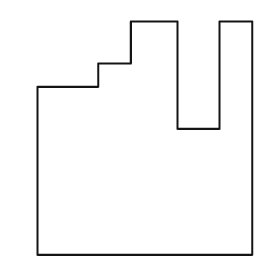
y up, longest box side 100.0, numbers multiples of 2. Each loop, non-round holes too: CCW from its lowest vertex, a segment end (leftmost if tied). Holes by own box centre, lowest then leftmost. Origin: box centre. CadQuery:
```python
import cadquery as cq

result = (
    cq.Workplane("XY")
    .moveTo(-46.0, -50.0)
    .lineTo(46.0, -50.0)
    .lineTo(46.0, 50.0)
    .lineTo(32.0, 50.0)
    .lineTo(32.0, 4.0)
    .lineTo(14.0, 4.0)
    .lineTo(14.0, 50.0)
    .lineTo(-6.0, 50.0)
    .lineTo(-6.0, 32.0)
    .lineTo(-20.0, 32.0)
    .lineTo(-20.0, 22.0)
    .lineTo(-46.0, 22.0)
    .close()
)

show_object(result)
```